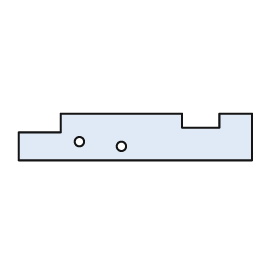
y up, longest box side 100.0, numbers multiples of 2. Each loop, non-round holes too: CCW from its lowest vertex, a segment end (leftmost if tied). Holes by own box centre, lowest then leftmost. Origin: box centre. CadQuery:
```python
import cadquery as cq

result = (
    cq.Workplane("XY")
    .moveTo(-50.0, -10.0)
    .lineTo(50.0, -10.0)
    .lineTo(50.0, 10.0)
    .lineTo(36.0, 10.0)
    .lineTo(36.0, 4.0)
    .lineTo(20.0, 4.0)
    .lineTo(20.0, 10.0)
    .lineTo(-32.0, 10.0)
    .lineTo(-32.0, 2.0)
    .lineTo(-50.0, 2.0)
    .close()
    .moveTo(-6.0, -4.0)
    .circle(2.0)
    .moveTo(-24.0, -2.0)
    .circle(2.0)
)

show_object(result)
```